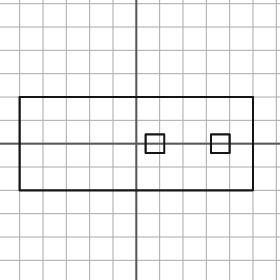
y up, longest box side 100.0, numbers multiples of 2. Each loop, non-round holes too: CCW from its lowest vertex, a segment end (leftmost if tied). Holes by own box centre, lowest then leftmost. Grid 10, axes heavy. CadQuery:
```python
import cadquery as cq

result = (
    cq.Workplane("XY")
    .moveTo(-50.0, -20.0)
    .lineTo(50.0, -20.0)
    .lineTo(50.0, 20.0)
    .lineTo(-50.0, 20.0)
    .close()
    .moveTo(4.0, -4.0)
    .lineTo(12.0, -4.0)
    .lineTo(12.0, 4.0)
    .lineTo(4.0, 4.0)
    .close()
    .moveTo(32.0, -4.0)
    .lineTo(40.0, -4.0)
    .lineTo(40.0, 4.0)
    .lineTo(32.0, 4.0)
    .close()
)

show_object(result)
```